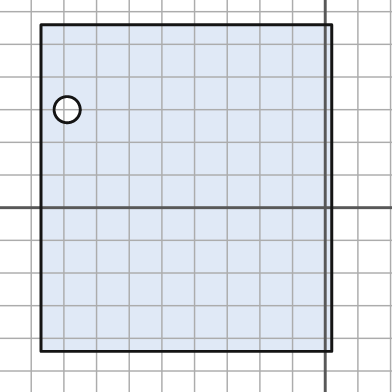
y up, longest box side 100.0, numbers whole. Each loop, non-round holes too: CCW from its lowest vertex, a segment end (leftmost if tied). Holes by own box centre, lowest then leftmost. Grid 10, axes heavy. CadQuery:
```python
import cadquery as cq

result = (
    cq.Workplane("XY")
    .moveTo(-87.0, -44.0)
    .lineTo(2.0, -44.0)
    .lineTo(2.0, 56.0)
    .lineTo(-87.0, 56.0)
    .close()
    .moveTo(-79.0, 30.0)
    .circle(4.0)
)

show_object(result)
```